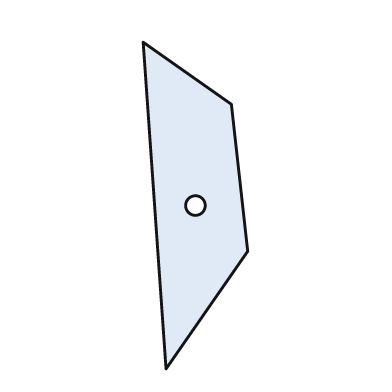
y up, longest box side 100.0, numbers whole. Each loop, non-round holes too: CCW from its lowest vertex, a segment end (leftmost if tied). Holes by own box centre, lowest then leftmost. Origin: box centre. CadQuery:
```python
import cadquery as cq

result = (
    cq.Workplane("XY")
    .moveTo(-9.0, -50.0)
    .lineTo(16.0, -14.0)
    .lineTo(11.0, 31.0)
    .lineTo(-16.0, 50.0)
    .close()
    .moveTo(0.0, 0.0)
    .circle(3.0)
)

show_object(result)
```